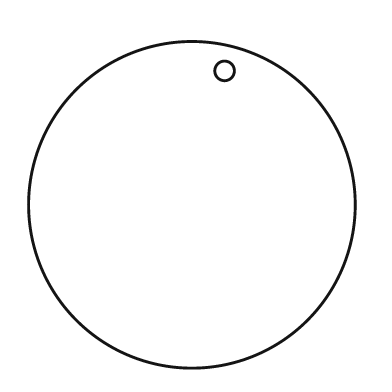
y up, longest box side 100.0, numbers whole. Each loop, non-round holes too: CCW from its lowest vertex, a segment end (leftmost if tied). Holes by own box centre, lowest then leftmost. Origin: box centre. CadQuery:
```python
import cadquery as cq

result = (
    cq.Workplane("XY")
    .moveTo(0.0, 0.0)
    .circle(50.0)
    .moveTo(10.0, 41.0)
    .circle(3.0)
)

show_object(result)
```